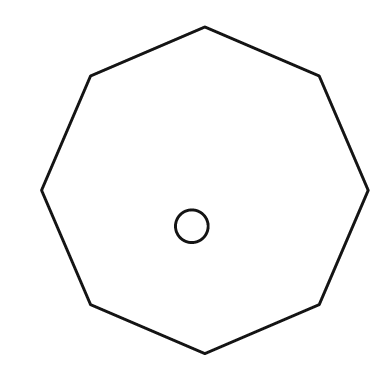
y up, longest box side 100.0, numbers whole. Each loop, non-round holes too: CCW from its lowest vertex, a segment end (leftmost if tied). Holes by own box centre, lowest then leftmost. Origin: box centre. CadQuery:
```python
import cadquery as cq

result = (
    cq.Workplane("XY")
    .moveTo(0.0, -50.0)
    .lineTo(35.0, -35.0)
    .lineTo(50.0, 0.0)
    .lineTo(35.0, 35.0)
    .lineTo(0.0, 50.0)
    .lineTo(-35.0, 35.0)
    .lineTo(-50.0, 0.0)
    .lineTo(-35.0, -35.0)
    .close()
    .moveTo(-4.0, -11.0)
    .circle(5.0)
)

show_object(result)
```